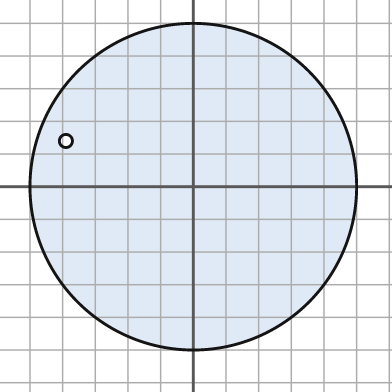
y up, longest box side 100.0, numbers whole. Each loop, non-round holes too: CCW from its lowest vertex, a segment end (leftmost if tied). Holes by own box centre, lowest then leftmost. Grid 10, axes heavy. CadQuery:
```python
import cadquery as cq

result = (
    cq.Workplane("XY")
    .moveTo(0.0, 0.0)
    .circle(50.0)
    .moveTo(-39.0, 14.0)
    .circle(2.0)
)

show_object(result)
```